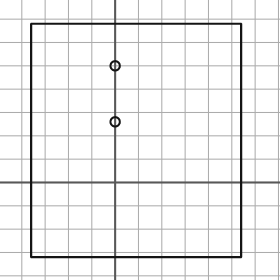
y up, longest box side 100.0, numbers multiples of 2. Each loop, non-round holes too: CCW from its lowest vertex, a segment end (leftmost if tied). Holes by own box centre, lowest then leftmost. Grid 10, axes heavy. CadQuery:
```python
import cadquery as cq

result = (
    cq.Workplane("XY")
    .moveTo(-36.0, -32.0)
    .lineTo(54.0, -32.0)
    .lineTo(54.0, 68.0)
    .lineTo(-36.0, 68.0)
    .close()
    .moveTo(0.0, 26.0)
    .circle(2.0)
    .moveTo(0.0, 50.0)
    .circle(2.0)
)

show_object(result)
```